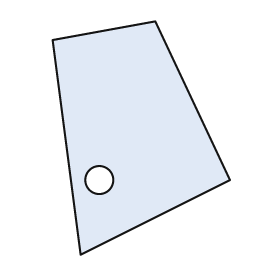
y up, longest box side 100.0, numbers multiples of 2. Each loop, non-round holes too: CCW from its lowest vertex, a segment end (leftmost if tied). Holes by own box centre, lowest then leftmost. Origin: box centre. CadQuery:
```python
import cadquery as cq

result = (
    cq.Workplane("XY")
    .moveTo(-26.0, -50.0)
    .lineTo(38.0, -18.0)
    .lineTo(6.0, 50.0)
    .lineTo(-38.0, 42.0)
    .close()
    .moveTo(-18.0, -18.0)
    .circle(6.0)
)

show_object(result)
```